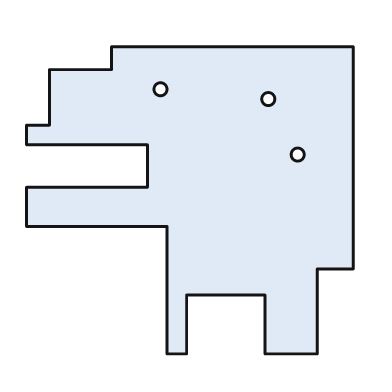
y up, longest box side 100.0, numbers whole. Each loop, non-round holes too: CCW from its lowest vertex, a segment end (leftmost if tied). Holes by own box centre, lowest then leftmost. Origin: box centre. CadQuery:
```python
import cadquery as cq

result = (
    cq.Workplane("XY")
    .moveTo(-7.0, -47.0)
    .lineTo(-1.0, -47.0)
    .lineTo(-1.0, -29.0)
    .lineTo(23.0, -29.0)
    .lineTo(23.0, -47.0)
    .lineTo(39.0, -47.0)
    .lineTo(39.0, -21.0)
    .lineTo(50.0, -21.0)
    .lineTo(50.0, 47.0)
    .lineTo(-24.0, 47.0)
    .lineTo(-24.0, 40.0)
    .lineTo(-43.0, 40.0)
    .lineTo(-43.0, 23.0)
    .lineTo(-50.0, 23.0)
    .lineTo(-50.0, 17.0)
    .lineTo(-13.0, 17.0)
    .lineTo(-13.0, 4.0)
    .lineTo(-50.0, 4.0)
    .lineTo(-50.0, -8.0)
    .lineTo(-7.0, -8.0)
    .close()
    .moveTo(33.0, 14.0)
    .circle(2.0)
    .moveTo(24.0, 31.0)
    .circle(2.0)
    .moveTo(-9.0, 34.0)
    .circle(2.0)
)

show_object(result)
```